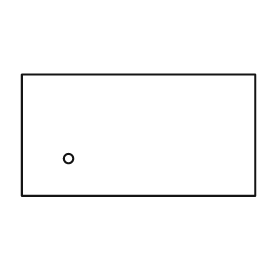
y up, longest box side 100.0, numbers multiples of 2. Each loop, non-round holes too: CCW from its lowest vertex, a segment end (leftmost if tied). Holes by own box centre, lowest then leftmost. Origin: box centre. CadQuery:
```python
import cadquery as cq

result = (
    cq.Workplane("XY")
    .moveTo(-50.0, -26.0)
    .lineTo(50.0, -26.0)
    .lineTo(50.0, 26.0)
    .lineTo(-50.0, 26.0)
    .close()
    .moveTo(-30.0, -10.0)
    .circle(2.0)
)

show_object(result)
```